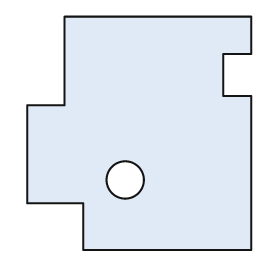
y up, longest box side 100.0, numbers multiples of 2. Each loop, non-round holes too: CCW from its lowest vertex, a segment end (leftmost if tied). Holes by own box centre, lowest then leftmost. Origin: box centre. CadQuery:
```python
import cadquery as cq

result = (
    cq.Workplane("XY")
    .moveTo(-24.0, -50.0)
    .lineTo(48.0, -50.0)
    .lineTo(48.0, 16.0)
    .lineTo(36.0, 16.0)
    .lineTo(36.0, 34.0)
    .lineTo(48.0, 34.0)
    .lineTo(48.0, 50.0)
    .lineTo(-32.0, 50.0)
    .lineTo(-32.0, 12.0)
    .lineTo(-48.0, 12.0)
    .lineTo(-48.0, -30.0)
    .lineTo(-24.0, -30.0)
    .close()
    .moveTo(-6.0, -20.0)
    .circle(8.0)
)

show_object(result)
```